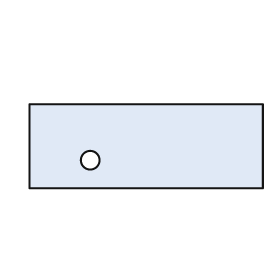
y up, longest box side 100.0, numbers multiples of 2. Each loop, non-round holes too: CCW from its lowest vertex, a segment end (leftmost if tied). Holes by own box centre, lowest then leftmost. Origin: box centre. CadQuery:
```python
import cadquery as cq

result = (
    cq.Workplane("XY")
    .moveTo(-50.0, -18.0)
    .lineTo(50.0, -18.0)
    .lineTo(50.0, 18.0)
    .lineTo(-50.0, 18.0)
    .close()
    .moveTo(-24.0, -6.0)
    .circle(4.0)
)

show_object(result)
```